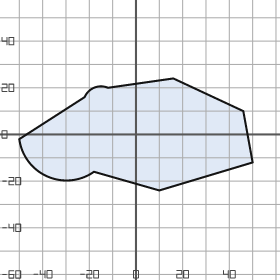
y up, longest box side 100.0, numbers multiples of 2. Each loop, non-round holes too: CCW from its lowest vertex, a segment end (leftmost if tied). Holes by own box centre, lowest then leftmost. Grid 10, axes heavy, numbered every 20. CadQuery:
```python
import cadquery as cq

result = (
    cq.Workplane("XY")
    .moveTo(10.0, -24.0)
    .lineTo(50.0, -12.0)
    .lineTo(46.0, 10.0)
    .lineTo(16.0, 24.0)
    .lineTo(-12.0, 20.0)
    .threePointArc((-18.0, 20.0), (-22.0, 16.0))
    .lineTo(-50.0, -2.0)
    .threePointArc((-38.0, -18.0), (-18.0, -16.0))
    .close()
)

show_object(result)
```